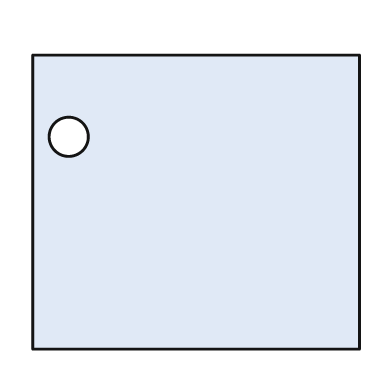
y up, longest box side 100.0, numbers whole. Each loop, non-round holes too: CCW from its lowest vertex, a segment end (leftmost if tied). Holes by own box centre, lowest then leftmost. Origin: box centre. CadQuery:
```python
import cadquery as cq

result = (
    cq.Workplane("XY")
    .moveTo(-50.0, -45.0)
    .lineTo(50.0, -45.0)
    .lineTo(50.0, 45.0)
    .lineTo(-50.0, 45.0)
    .close()
    .moveTo(-39.0, 20.0)
    .circle(6.0)
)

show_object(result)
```